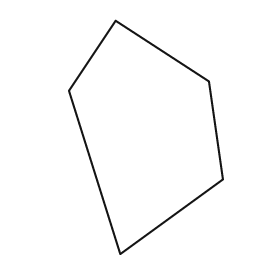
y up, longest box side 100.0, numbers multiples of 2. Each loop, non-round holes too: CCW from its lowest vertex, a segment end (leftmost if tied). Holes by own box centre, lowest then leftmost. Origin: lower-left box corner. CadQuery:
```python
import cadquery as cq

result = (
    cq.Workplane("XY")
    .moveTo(22.0, 0.0)
    .lineTo(66.0, 32.0)
    .lineTo(60.0, 74.0)
    .lineTo(20.0, 100.0)
    .lineTo(0.0, 70.0)
    .close()
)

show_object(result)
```